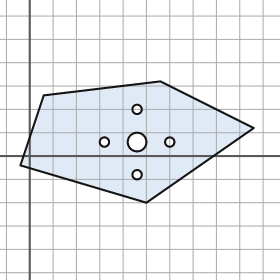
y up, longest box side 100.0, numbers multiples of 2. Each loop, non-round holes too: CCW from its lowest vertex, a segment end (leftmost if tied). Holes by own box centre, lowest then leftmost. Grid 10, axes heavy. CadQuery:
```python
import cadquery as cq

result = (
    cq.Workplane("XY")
    .moveTo(50.0, -20.0)
    .lineTo(96.0, 12.0)
    .lineTo(56.0, 32.0)
    .lineTo(6.0, 26.0)
    .lineTo(-4.0, -4.0)
    .close()
    .moveTo(46.0, -8.0)
    .circle(2.0)
    .moveTo(32.0, 6.0)
    .circle(2.0)
    .moveTo(46.0, 6.0)
    .circle(4.0)
    .moveTo(60.0, 6.0)
    .circle(2.0)
    .moveTo(46.0, 20.0)
    .circle(2.0)
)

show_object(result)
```